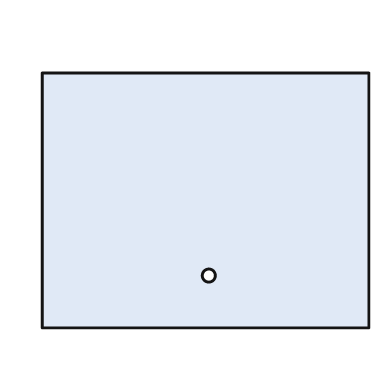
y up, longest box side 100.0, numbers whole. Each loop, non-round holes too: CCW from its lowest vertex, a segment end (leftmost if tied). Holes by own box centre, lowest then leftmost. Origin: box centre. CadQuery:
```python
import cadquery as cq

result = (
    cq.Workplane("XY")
    .moveTo(-50.0, -39.0)
    .lineTo(50.0, -39.0)
    .lineTo(50.0, 39.0)
    .lineTo(-50.0, 39.0)
    .close()
    .moveTo(1.0, -23.0)
    .circle(2.0)
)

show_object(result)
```